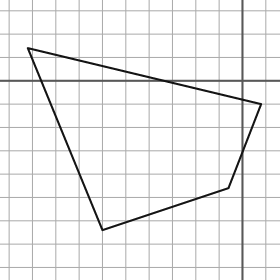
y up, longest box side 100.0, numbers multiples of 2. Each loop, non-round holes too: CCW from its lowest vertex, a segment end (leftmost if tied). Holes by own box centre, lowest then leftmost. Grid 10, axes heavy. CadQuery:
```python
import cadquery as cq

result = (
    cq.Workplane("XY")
    .moveTo(-60.0, -64.0)
    .lineTo(-6.0, -46.0)
    .lineTo(8.0, -10.0)
    .lineTo(-92.0, 14.0)
    .close()
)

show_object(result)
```